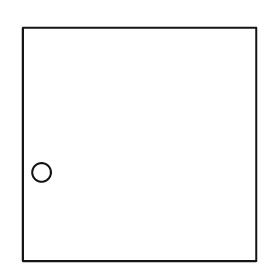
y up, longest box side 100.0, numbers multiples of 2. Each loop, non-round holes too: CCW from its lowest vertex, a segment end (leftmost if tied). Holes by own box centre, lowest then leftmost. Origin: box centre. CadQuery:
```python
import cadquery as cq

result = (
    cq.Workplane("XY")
    .moveTo(-50.0, -50.0)
    .lineTo(50.0, -50.0)
    .lineTo(50.0, 50.0)
    .lineTo(-50.0, 50.0)
    .close()
    .moveTo(-42.0, -12.0)
    .circle(4.0)
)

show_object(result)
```